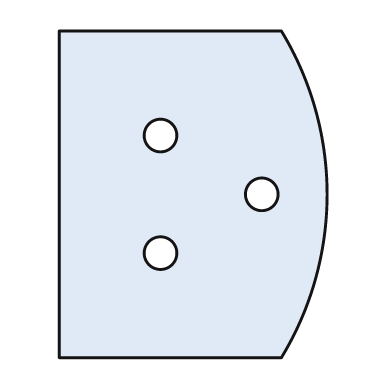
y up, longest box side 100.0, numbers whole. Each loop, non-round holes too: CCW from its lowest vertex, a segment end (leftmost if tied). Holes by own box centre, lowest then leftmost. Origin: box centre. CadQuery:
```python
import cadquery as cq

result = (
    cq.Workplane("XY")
    .moveTo(-41.0, -50.0)
    .lineTo(27.0, -50.0)
    .threePointArc((41.0, 0.0), (27.0, 50.0))
    .lineTo(-41.0, 50.0)
    .close()
    .moveTo(-10.0, -18.0)
    .circle(5.0)
    .moveTo(21.0, 0.0)
    .circle(5.0)
    .moveTo(-10.0, 18.0)
    .circle(5.0)
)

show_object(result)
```